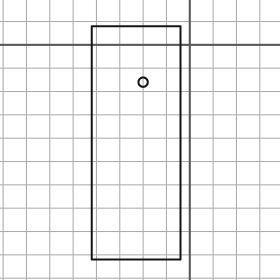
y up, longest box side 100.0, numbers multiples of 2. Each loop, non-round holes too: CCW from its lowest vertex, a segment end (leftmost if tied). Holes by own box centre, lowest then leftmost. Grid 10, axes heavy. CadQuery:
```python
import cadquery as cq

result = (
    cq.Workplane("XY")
    .moveTo(-42.0, -92.0)
    .lineTo(-4.0, -92.0)
    .lineTo(-4.0, 8.0)
    .lineTo(-42.0, 8.0)
    .close()
    .moveTo(-20.0, -16.0)
    .circle(2.0)
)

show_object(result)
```